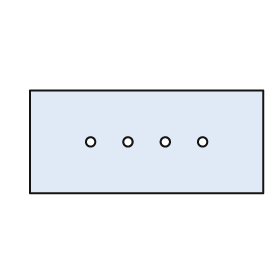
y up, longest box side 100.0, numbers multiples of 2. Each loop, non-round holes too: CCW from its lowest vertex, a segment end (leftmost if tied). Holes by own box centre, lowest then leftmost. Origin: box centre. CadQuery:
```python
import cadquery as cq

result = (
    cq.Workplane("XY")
    .moveTo(-50.0, -22.0)
    .lineTo(50.0, -22.0)
    .lineTo(50.0, 22.0)
    .lineTo(-50.0, 22.0)
    .close()
    .moveTo(-24.0, 0.0)
    .circle(2.0)
    .moveTo(-8.0, 0.0)
    .circle(2.0)
    .moveTo(8.0, 0.0)
    .circle(2.0)
    .moveTo(24.0, 0.0)
    .circle(2.0)
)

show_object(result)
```